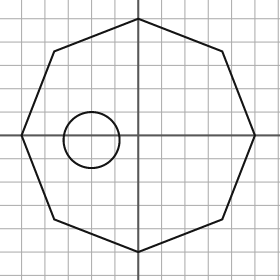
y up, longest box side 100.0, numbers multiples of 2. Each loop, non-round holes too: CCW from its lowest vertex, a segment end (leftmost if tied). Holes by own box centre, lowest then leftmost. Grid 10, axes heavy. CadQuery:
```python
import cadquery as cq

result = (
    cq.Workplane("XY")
    .moveTo(0.0, -50.0)
    .lineTo(36.0, -36.0)
    .lineTo(50.0, 0.0)
    .lineTo(36.0, 36.0)
    .lineTo(0.0, 50.0)
    .lineTo(-36.0, 36.0)
    .lineTo(-50.0, 0.0)
    .lineTo(-36.0, -36.0)
    .close()
    .moveTo(-20.0, -2.0)
    .circle(12.0)
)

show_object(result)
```